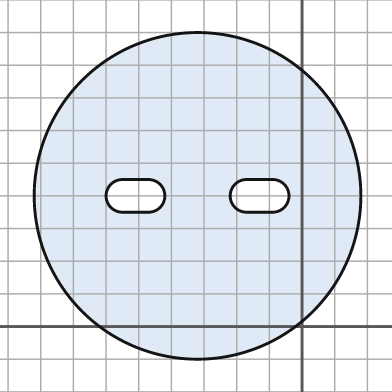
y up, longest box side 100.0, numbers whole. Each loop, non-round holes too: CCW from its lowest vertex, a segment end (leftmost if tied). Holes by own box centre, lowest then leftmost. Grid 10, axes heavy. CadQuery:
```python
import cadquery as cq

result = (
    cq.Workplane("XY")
    .moveTo(-32.0, 40.0)
    .circle(50.0)
    .moveTo(-55.0, 35.0)
    .lineTo(-47.0, 35.0)
    .threePointArc((-42.0, 40.0), (-47.0, 45.0))
    .lineTo(-55.0, 45.0)
    .threePointArc((-60.0, 40.0), (-55.0, 35.0))
    .close()
    .moveTo(-17.0, 35.0)
    .lineTo(-9.0, 35.0)
    .threePointArc((-4.0, 40.0), (-9.0, 45.0))
    .lineTo(-17.0, 45.0)
    .threePointArc((-22.0, 40.0), (-17.0, 35.0))
    .close()
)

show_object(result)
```